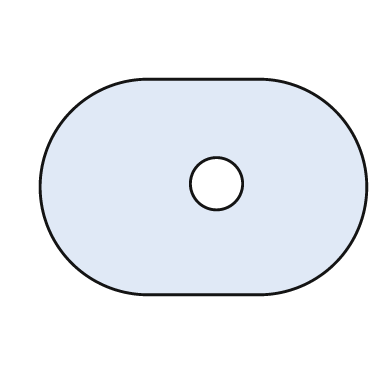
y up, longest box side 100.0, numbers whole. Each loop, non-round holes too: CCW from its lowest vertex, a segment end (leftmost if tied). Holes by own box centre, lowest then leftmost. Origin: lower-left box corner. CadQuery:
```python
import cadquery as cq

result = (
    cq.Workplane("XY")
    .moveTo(33.0, 0.0)
    .lineTo(67.0, 0.0)
    .threePointArc((100.0, 33.0), (67.0, 66.0))
    .lineTo(33.0, 66.0)
    .threePointArc((0.0, 33.0), (33.0, 0.0))
    .close()
    .moveTo(54.0, 34.0)
    .circle(8.0)
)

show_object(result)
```